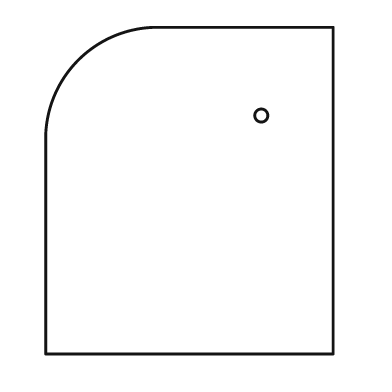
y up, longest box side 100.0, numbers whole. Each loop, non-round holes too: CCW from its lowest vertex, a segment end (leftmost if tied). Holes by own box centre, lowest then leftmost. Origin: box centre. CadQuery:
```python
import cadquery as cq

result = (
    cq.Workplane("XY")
    .moveTo(-44.0, -50.0)
    .lineTo(44.0, -50.0)
    .lineTo(44.0, 50.0)
    .lineTo(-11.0, 50.0)
    .threePointArc((-34.0, 40.0), (-44.0, 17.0))
    .close()
    .moveTo(22.0, 23.0)
    .circle(2.0)
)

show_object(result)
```